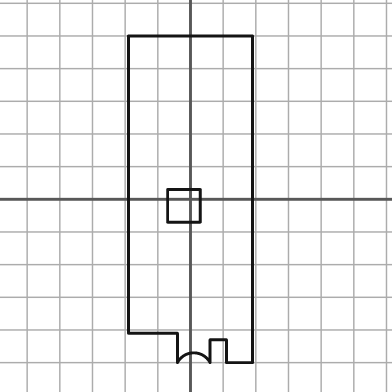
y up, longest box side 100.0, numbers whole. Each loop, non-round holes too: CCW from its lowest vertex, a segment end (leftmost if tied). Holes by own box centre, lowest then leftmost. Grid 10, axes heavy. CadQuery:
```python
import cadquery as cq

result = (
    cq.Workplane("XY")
    .moveTo(-4.0, -50.0)
    .threePointArc((1.0, -47.0), (6.0, -50.0))
    .lineTo(6.0, -43.0)
    .lineTo(11.0, -43.0)
    .lineTo(11.0, -50.0)
    .lineTo(19.0, -50.0)
    .lineTo(19.0, 50.0)
    .lineTo(-19.0, 50.0)
    .lineTo(-19.0, -41.0)
    .lineTo(-4.0, -41.0)
    .close()
    .moveTo(-7.0, -7.0)
    .lineTo(3.0, -7.0)
    .lineTo(3.0, 3.0)
    .lineTo(-7.0, 3.0)
    .close()
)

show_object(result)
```